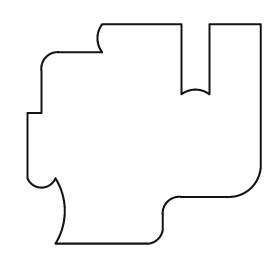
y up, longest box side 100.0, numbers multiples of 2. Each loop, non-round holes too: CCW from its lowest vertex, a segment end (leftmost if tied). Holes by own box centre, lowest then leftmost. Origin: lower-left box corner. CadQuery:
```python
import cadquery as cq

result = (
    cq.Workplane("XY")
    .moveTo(12.0, 0.0)
    .lineTo(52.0, 0.0)
    .threePointArc((56.0, 2.0), (58.0, 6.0))
    .lineTo(58.0, 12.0)
    .threePointArc((60.0, 18.0), (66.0, 20.0))
    .lineTo(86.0, 20.0)
    .threePointArc((96.0, 24.0), (100.0, 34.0))
    .lineTo(100.0, 94.0)
    .lineTo(78.0, 94.0)
    .lineTo(78.0, 64.0)
    .threePointArc((72.0, 66.0), (66.0, 64.0))
    .lineTo(66.0, 94.0)
    .lineTo(32.0, 94.0)
    .threePointArc((30.0, 88.0), (32.0, 82.0))
    .lineTo(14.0, 82.0)
    .threePointArc((8.0, 80.0), (6.0, 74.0))
    .lineTo(6.0, 56.0)
    .lineTo(0.0, 56.0)
    .lineTo(0.0, 28.0)
    .threePointArc((6.0, 24.0), (12.0, 28.0))
    .threePointArc((16.0, 14.0), (12.0, 0.0))
    .close()
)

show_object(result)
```